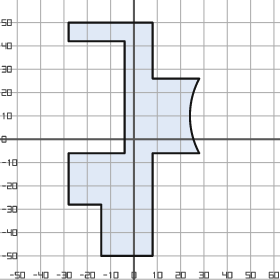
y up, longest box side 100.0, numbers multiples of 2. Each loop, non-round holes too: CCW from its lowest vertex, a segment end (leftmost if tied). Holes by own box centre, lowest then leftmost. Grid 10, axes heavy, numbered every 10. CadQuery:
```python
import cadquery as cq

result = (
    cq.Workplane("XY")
    .moveTo(-14.0, -50.0)
    .lineTo(8.0, -50.0)
    .lineTo(8.0, -6.0)
    .lineTo(28.0, -6.0)
    .threePointArc((24.0, 10.0), (28.0, 26.0))
    .lineTo(8.0, 26.0)
    .lineTo(8.0, 50.0)
    .lineTo(-28.0, 50.0)
    .lineTo(-28.0, 42.0)
    .lineTo(-4.0, 42.0)
    .lineTo(-4.0, -6.0)
    .lineTo(-28.0, -6.0)
    .lineTo(-28.0, -28.0)
    .lineTo(-14.0, -28.0)
    .close()
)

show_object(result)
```